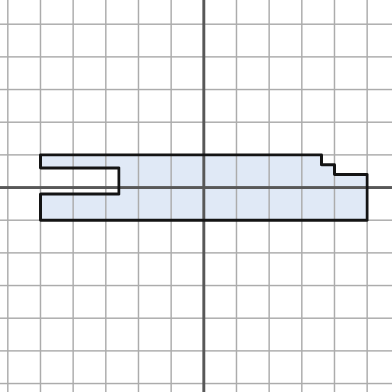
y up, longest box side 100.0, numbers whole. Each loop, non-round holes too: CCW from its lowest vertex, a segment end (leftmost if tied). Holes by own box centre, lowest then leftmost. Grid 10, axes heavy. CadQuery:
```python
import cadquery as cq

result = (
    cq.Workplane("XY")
    .moveTo(-50.0, -10.0)
    .lineTo(50.0, -10.0)
    .lineTo(50.0, 4.0)
    .lineTo(40.0, 4.0)
    .lineTo(40.0, 7.0)
    .lineTo(36.0, 7.0)
    .lineTo(36.0, 10.0)
    .lineTo(-50.0, 10.0)
    .lineTo(-50.0, 6.0)
    .lineTo(-26.0, 6.0)
    .lineTo(-26.0, -2.0)
    .lineTo(-50.0, -2.0)
    .close()
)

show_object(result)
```